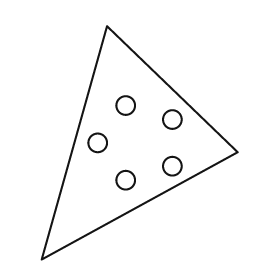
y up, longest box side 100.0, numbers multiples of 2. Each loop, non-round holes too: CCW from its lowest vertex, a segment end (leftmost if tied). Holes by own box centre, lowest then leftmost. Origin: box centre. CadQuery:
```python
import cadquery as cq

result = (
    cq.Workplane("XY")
    .moveTo(-42.0, -50.0)
    .lineTo(42.0, -4.0)
    .lineTo(-14.0, 50.0)
    .close()
    .moveTo(-6.0, -16.0)
    .circle(4.0)
    .moveTo(14.0, -10.0)
    .circle(4.0)
    .moveTo(-18.0, 0.0)
    .circle(4.0)
    .moveTo(14.0, 10.0)
    .circle(4.0)
    .moveTo(-6.0, 16.0)
    .circle(4.0)
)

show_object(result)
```